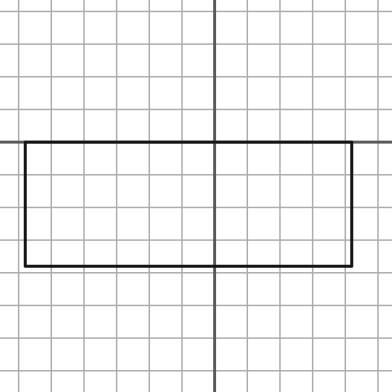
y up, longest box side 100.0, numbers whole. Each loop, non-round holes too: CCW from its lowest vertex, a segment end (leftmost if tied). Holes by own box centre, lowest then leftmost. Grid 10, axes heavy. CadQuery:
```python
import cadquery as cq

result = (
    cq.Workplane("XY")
    .moveTo(-58.0, -38.0)
    .lineTo(42.0, -38.0)
    .lineTo(42.0, 0.0)
    .lineTo(-58.0, 0.0)
    .close()
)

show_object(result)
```